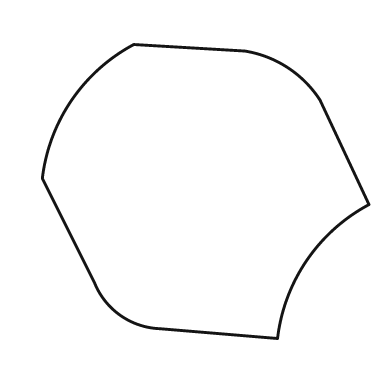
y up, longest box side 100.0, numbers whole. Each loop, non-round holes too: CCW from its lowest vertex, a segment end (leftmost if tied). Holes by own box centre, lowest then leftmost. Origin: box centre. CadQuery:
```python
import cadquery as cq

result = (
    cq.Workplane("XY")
    .moveTo(22.0, -45.0)
    .threePointArc((31.0, -21.0), (50.0, -4.0))
    .lineTo(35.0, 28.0)
    .threePointArc((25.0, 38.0), (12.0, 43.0))
    .lineTo(-22.0, 45.0)
    .threePointArc((-41.0, 28.0), (-50.0, 4.0))
    .lineTo(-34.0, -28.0)
    .threePointArc((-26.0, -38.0), (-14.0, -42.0))
    .close()
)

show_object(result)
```